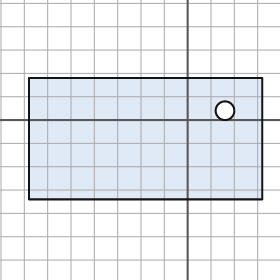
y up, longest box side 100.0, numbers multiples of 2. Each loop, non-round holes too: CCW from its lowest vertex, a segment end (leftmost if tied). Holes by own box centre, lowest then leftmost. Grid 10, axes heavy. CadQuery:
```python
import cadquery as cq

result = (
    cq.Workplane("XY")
    .moveTo(-68.0, -34.0)
    .lineTo(32.0, -34.0)
    .lineTo(32.0, 18.0)
    .lineTo(-68.0, 18.0)
    .close()
    .moveTo(16.0, 4.0)
    .circle(4.0)
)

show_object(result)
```